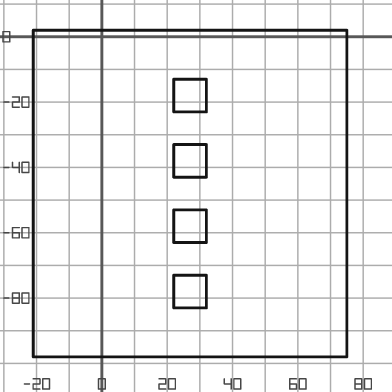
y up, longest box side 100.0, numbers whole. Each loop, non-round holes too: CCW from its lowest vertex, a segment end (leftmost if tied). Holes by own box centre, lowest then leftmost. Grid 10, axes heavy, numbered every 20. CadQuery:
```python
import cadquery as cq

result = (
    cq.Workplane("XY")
    .moveTo(-21.0, -98.0)
    .lineTo(75.0, -98.0)
    .lineTo(75.0, 2.0)
    .lineTo(-21.0, 2.0)
    .close()
    .moveTo(22.0, -83.0)
    .lineTo(32.0, -83.0)
    .lineTo(32.0, -73.0)
    .lineTo(22.0, -73.0)
    .close()
    .moveTo(22.0, -63.0)
    .lineTo(32.0, -63.0)
    .lineTo(32.0, -53.0)
    .lineTo(22.0, -53.0)
    .close()
    .moveTo(22.0, -43.0)
    .lineTo(32.0, -43.0)
    .lineTo(32.0, -33.0)
    .lineTo(22.0, -33.0)
    .close()
    .moveTo(22.0, -23.0)
    .lineTo(32.0, -23.0)
    .lineTo(32.0, -13.0)
    .lineTo(22.0, -13.0)
    .close()
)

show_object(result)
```